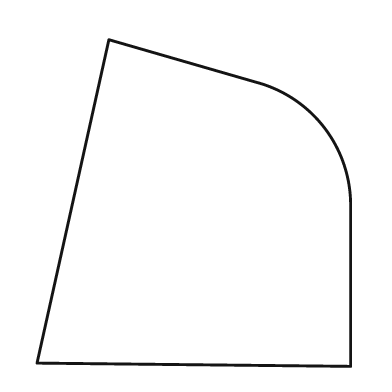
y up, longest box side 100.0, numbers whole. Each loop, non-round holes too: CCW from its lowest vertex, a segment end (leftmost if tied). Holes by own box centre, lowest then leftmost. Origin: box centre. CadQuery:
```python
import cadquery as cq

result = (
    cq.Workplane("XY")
    .moveTo(48.0, -50.0)
    .lineTo(48.0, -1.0)
    .threePointArc((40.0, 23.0), (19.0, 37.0))
    .lineTo(-26.0, 50.0)
    .lineTo(-48.0, -49.0)
    .close()
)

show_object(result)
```